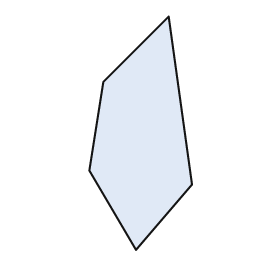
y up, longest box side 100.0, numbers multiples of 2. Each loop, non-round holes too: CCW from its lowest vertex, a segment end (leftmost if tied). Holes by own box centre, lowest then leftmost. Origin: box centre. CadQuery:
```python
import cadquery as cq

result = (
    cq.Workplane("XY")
    .moveTo(-2.0, -50.0)
    .lineTo(22.0, -22.0)
    .lineTo(12.0, 50.0)
    .lineTo(-16.0, 22.0)
    .lineTo(-22.0, -16.0)
    .close()
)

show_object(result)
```